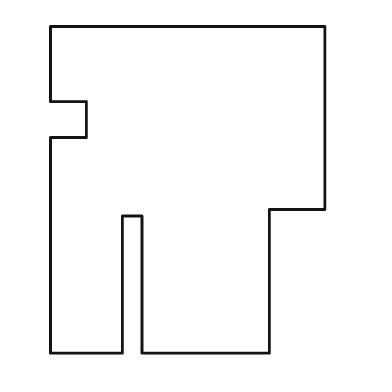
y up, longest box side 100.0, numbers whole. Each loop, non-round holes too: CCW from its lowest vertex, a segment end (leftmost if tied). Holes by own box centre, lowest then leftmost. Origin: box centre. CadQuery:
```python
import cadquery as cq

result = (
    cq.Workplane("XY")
    .moveTo(-42.0, -50.0)
    .lineTo(-20.0, -50.0)
    .lineTo(-20.0, -8.0)
    .lineTo(-14.0, -8.0)
    .lineTo(-14.0, -50.0)
    .lineTo(25.0, -50.0)
    .lineTo(25.0, -6.0)
    .lineTo(42.0, -6.0)
    .lineTo(42.0, 50.0)
    .lineTo(-42.0, 50.0)
    .lineTo(-42.0, 27.0)
    .lineTo(-31.0, 27.0)
    .lineTo(-31.0, 16.0)
    .lineTo(-42.0, 16.0)
    .close()
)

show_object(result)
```